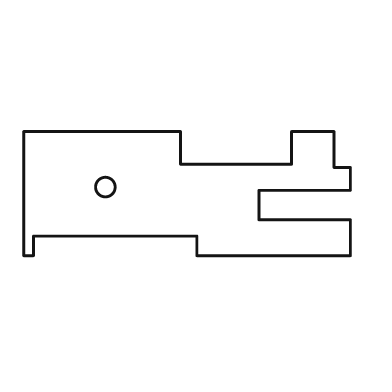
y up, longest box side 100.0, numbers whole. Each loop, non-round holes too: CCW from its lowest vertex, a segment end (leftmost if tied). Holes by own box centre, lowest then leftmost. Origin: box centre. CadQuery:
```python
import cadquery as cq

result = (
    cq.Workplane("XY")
    .moveTo(-50.0, -19.0)
    .lineTo(-47.0, -19.0)
    .lineTo(-47.0, -13.0)
    .lineTo(3.0, -13.0)
    .lineTo(3.0, -19.0)
    .lineTo(50.0, -19.0)
    .lineTo(50.0, -8.0)
    .lineTo(22.0, -8.0)
    .lineTo(22.0, 1.0)
    .lineTo(50.0, 1.0)
    .lineTo(50.0, 8.0)
    .lineTo(45.0, 8.0)
    .lineTo(45.0, 19.0)
    .lineTo(32.0, 19.0)
    .lineTo(32.0, 9.0)
    .lineTo(-2.0, 9.0)
    .lineTo(-2.0, 19.0)
    .lineTo(-50.0, 19.0)
    .close()
    .moveTo(-25.0, 2.0)
    .circle(3.0)
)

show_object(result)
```